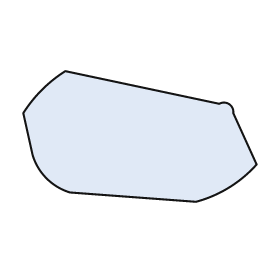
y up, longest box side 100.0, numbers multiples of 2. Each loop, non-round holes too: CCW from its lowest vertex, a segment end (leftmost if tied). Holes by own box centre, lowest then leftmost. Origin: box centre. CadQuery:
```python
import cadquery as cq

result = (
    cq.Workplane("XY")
    .moveTo(24.0, -28.0)
    .threePointArc((38.0, -22.0), (50.0, -12.0))
    .lineTo(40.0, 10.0)
    .threePointArc((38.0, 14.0), (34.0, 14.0))
    .lineTo(-32.0, 28.0)
    .threePointArc((-42.0, 20.0), (-50.0, 10.0))
    .lineTo(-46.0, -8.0)
    .threePointArc((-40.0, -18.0), (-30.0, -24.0))
    .close()
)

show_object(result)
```